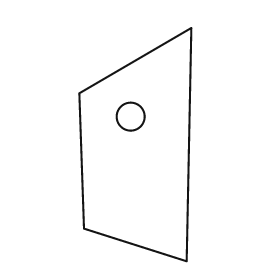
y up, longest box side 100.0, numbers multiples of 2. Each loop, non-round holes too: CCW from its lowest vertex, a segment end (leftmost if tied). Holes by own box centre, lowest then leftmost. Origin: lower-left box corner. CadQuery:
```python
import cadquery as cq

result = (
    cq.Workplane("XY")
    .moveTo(46.0, 0.0)
    .lineTo(48.0, 100.0)
    .lineTo(0.0, 72.0)
    .lineTo(2.0, 14.0)
    .close()
    .moveTo(22.0, 62.0)
    .circle(6.0)
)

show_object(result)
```